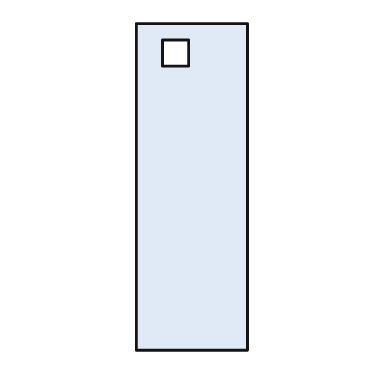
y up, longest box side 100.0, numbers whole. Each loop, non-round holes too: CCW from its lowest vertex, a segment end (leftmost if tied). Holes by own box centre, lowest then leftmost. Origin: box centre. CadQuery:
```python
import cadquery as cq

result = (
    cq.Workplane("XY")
    .moveTo(-17.0, -50.0)
    .lineTo(17.0, -50.0)
    .lineTo(17.0, 50.0)
    .lineTo(-17.0, 50.0)
    .close()
    .moveTo(-9.0, 37.0)
    .lineTo(-1.0, 37.0)
    .lineTo(-1.0, 45.0)
    .lineTo(-9.0, 45.0)
    .close()
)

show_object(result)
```